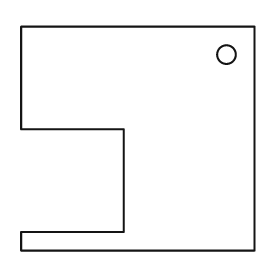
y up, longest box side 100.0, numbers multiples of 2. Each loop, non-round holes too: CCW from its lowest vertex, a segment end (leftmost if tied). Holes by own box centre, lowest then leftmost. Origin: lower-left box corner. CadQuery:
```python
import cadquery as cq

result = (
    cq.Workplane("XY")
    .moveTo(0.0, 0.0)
    .lineTo(100.0, 0.0)
    .lineTo(100.0, 96.0)
    .lineTo(0.0, 96.0)
    .lineTo(0.0, 52.0)
    .lineTo(44.0, 52.0)
    .lineTo(44.0, 8.0)
    .lineTo(0.0, 8.0)
    .close()
    .moveTo(88.0, 84.0)
    .circle(4.0)
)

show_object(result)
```